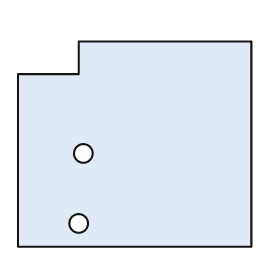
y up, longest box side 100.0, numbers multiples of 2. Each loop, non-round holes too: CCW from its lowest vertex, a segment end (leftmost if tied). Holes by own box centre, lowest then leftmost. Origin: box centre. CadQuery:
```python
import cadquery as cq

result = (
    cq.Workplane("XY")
    .moveTo(-50.0, -44.0)
    .lineTo(50.0, -44.0)
    .lineTo(50.0, 44.0)
    .lineTo(-24.0, 44.0)
    .lineTo(-24.0, 30.0)
    .lineTo(-50.0, 30.0)
    .close()
    .moveTo(-24.0, -34.0)
    .circle(4.0)
    .moveTo(-22.0, -4.0)
    .circle(4.0)
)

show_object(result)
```